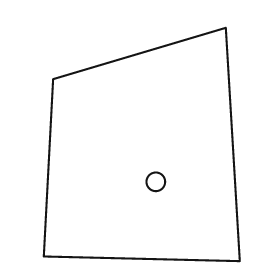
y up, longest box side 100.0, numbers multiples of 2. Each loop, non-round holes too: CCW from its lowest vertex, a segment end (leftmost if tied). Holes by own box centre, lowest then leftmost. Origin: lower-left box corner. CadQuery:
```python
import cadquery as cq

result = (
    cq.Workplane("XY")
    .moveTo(84.0, 0.0)
    .lineTo(78.0, 100.0)
    .lineTo(4.0, 78.0)
    .lineTo(0.0, 2.0)
    .close()
    .moveTo(48.0, 34.0)
    .circle(4.0)
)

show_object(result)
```